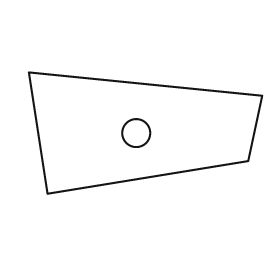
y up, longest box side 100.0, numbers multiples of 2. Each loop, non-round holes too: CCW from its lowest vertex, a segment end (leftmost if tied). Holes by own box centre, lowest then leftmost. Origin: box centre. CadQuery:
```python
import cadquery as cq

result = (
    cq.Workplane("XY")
    .moveTo(-42.0, -26.0)
    .lineTo(44.0, -12.0)
    .lineTo(50.0, 16.0)
    .lineTo(-50.0, 26.0)
    .close()
    .moveTo(-4.0, 0.0)
    .circle(6.0)
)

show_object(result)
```